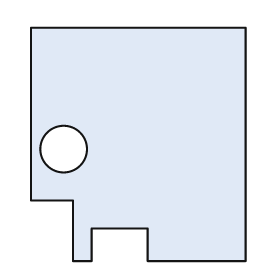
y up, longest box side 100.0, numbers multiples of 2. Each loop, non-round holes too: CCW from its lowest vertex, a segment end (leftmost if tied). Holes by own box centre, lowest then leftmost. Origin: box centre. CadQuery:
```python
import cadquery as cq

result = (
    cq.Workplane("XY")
    .moveTo(-28.0, -50.0)
    .lineTo(-20.0, -50.0)
    .lineTo(-20.0, -36.0)
    .lineTo(4.0, -36.0)
    .lineTo(4.0, -50.0)
    .lineTo(46.0, -50.0)
    .lineTo(46.0, 50.0)
    .lineTo(-46.0, 50.0)
    .lineTo(-46.0, -24.0)
    .lineTo(-28.0, -24.0)
    .close()
    .moveTo(-32.0, -2.0)
    .circle(10.0)
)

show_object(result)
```